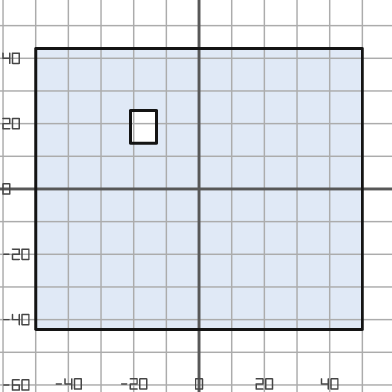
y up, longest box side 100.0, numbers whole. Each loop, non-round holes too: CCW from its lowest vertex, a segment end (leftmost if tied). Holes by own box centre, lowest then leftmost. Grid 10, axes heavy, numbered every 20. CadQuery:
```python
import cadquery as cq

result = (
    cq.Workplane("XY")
    .moveTo(-50.0, -43.0)
    .lineTo(50.0, -43.0)
    .lineTo(50.0, 43.0)
    .lineTo(-50.0, 43.0)
    .close()
    .moveTo(-21.0, 14.0)
    .lineTo(-13.0, 14.0)
    .lineTo(-13.0, 24.0)
    .lineTo(-21.0, 24.0)
    .close()
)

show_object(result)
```